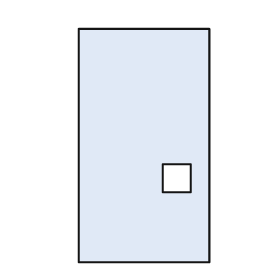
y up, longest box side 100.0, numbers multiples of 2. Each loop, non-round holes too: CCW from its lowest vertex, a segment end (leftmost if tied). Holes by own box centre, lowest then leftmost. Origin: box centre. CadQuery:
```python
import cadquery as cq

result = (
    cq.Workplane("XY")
    .moveTo(-28.0, -50.0)
    .lineTo(28.0, -50.0)
    .lineTo(28.0, 50.0)
    .lineTo(-28.0, 50.0)
    .close()
    .moveTo(8.0, -20.0)
    .lineTo(20.0, -20.0)
    .lineTo(20.0, -8.0)
    .lineTo(8.0, -8.0)
    .close()
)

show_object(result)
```